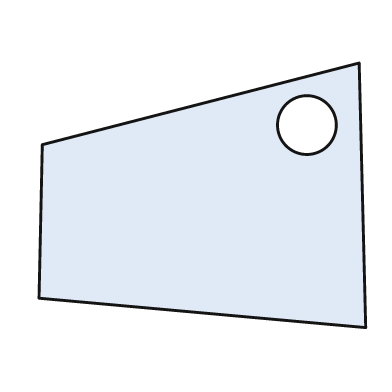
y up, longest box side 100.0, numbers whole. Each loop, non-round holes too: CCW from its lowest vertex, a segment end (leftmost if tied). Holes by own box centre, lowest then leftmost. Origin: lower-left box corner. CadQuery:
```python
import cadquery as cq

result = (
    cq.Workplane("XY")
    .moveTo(100.0, 0.0)
    .lineTo(98.0, 81.0)
    .lineTo(1.0, 56.0)
    .lineTo(0.0, 9.0)
    .close()
    .moveTo(82.0, 62.0)
    .circle(9.0)
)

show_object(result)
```